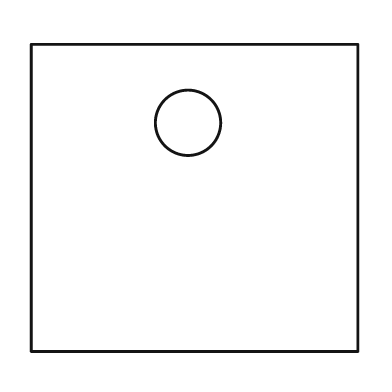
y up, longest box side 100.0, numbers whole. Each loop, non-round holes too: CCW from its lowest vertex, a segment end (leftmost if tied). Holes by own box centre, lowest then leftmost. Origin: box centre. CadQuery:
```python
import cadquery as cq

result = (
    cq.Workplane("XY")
    .moveTo(-50.0, -47.0)
    .lineTo(50.0, -47.0)
    .lineTo(50.0, 47.0)
    .lineTo(-50.0, 47.0)
    .close()
    .moveTo(-2.0, 23.0)
    .circle(10.0)
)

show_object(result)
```